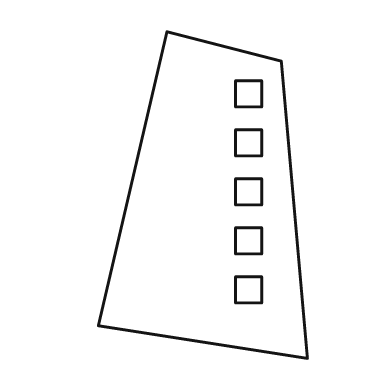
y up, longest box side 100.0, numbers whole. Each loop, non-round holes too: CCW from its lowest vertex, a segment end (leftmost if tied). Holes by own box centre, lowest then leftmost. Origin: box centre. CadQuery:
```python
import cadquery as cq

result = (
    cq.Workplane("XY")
    .moveTo(32.0, -50.0)
    .lineTo(24.0, 41.0)
    .lineTo(-11.0, 50.0)
    .lineTo(-32.0, -40.0)
    .close()
    .moveTo(10.0, -33.0)
    .lineTo(18.0, -33.0)
    .lineTo(18.0, -25.0)
    .lineTo(10.0, -25.0)
    .close()
    .moveTo(10.0, -18.0)
    .lineTo(18.0, -18.0)
    .lineTo(18.0, -10.0)
    .lineTo(10.0, -10.0)
    .close()
    .moveTo(10.0, -3.0)
    .lineTo(18.0, -3.0)
    .lineTo(18.0, 5.0)
    .lineTo(10.0, 5.0)
    .close()
    .moveTo(10.0, 12.0)
    .lineTo(18.0, 12.0)
    .lineTo(18.0, 20.0)
    .lineTo(10.0, 20.0)
    .close()
    .moveTo(10.0, 27.0)
    .lineTo(18.0, 27.0)
    .lineTo(18.0, 35.0)
    .lineTo(10.0, 35.0)
    .close()
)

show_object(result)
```